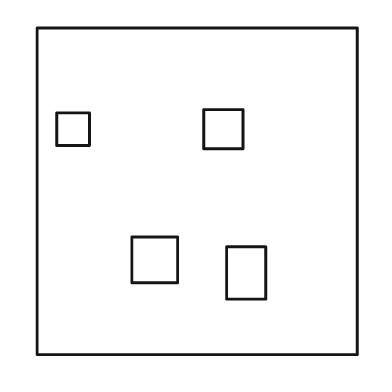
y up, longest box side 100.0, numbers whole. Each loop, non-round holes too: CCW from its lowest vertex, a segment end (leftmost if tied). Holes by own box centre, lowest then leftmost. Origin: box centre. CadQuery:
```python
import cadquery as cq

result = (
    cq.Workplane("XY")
    .moveTo(-49.0, -50.0)
    .lineTo(49.0, -50.0)
    .lineTo(49.0, 50.0)
    .lineTo(-49.0, 50.0)
    .close()
    .moveTo(9.0, -33.0)
    .lineTo(21.0, -33.0)
    .lineTo(21.0, -17.0)
    .lineTo(9.0, -17.0)
    .close()
    .moveTo(-20.0, -28.0)
    .lineTo(-6.0, -28.0)
    .lineTo(-6.0, -14.0)
    .lineTo(-20.0, -14.0)
    .close()
    .moveTo(-43.0, 14.0)
    .lineTo(-33.0, 14.0)
    .lineTo(-33.0, 24.0)
    .lineTo(-43.0, 24.0)
    .close()
    .moveTo(2.0, 13.0)
    .lineTo(14.0, 13.0)
    .lineTo(14.0, 25.0)
    .lineTo(2.0, 25.0)
    .close()
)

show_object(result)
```